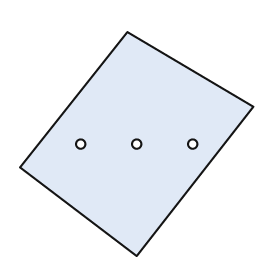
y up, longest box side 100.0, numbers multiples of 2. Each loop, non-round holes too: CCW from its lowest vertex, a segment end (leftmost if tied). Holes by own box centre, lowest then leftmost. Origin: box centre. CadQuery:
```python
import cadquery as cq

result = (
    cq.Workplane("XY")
    .moveTo(0.0, -48.0)
    .lineTo(50.0, 16.0)
    .lineTo(-4.0, 48.0)
    .lineTo(-50.0, -10.0)
    .close()
    .moveTo(-24.0, 0.0)
    .circle(2.0)
    .moveTo(0.0, 0.0)
    .circle(2.0)
    .moveTo(24.0, 0.0)
    .circle(2.0)
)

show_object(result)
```